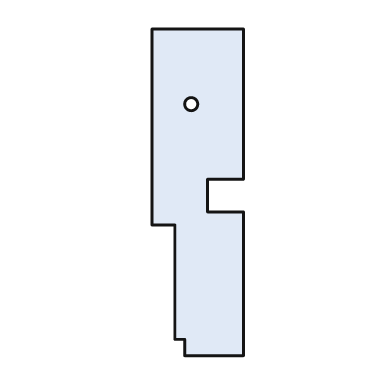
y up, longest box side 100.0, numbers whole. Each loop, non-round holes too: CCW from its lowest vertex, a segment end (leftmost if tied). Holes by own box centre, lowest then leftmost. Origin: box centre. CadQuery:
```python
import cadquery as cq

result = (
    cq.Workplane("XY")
    .moveTo(-4.0, -50.0)
    .lineTo(14.0, -50.0)
    .lineTo(14.0, -6.0)
    .lineTo(3.0, -6.0)
    .lineTo(3.0, 4.0)
    .lineTo(14.0, 4.0)
    .lineTo(14.0, 50.0)
    .lineTo(-14.0, 50.0)
    .lineTo(-14.0, -10.0)
    .lineTo(-7.0, -10.0)
    .lineTo(-7.0, -45.0)
    .lineTo(-4.0, -45.0)
    .close()
    .moveTo(-2.0, 27.0)
    .circle(2.0)
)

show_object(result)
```